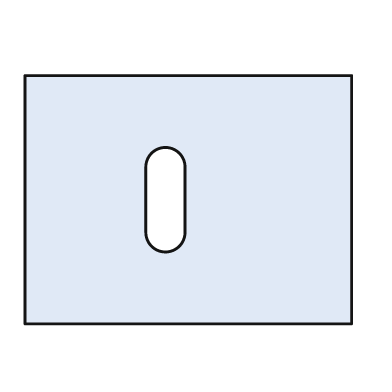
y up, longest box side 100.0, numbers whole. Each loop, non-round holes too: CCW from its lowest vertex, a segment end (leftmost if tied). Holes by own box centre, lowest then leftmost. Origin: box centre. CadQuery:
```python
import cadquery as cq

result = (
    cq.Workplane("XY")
    .moveTo(-50.0, -38.0)
    .lineTo(50.0, -38.0)
    .lineTo(50.0, 38.0)
    .lineTo(-50.0, 38.0)
    .close()
    .moveTo(-13.0, -10.0)
    .threePointArc((-7.0, -16.0), (-1.0, -10.0))
    .lineTo(-1.0, 10.0)
    .threePointArc((-7.0, 16.0), (-13.0, 10.0))
    .close()
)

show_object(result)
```